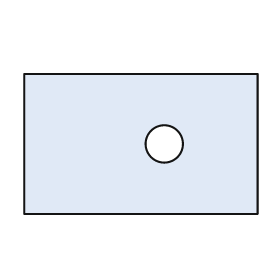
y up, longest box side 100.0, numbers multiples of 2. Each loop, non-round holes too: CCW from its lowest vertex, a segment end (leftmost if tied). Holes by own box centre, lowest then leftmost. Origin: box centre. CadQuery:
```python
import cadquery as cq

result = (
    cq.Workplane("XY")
    .moveTo(-50.0, -30.0)
    .lineTo(50.0, -30.0)
    .lineTo(50.0, 30.0)
    .lineTo(-50.0, 30.0)
    .close()
    .moveTo(10.0, 0.0)
    .circle(8.0)
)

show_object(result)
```